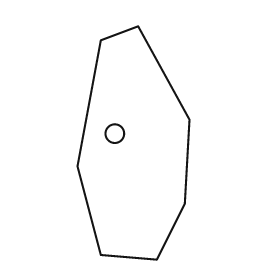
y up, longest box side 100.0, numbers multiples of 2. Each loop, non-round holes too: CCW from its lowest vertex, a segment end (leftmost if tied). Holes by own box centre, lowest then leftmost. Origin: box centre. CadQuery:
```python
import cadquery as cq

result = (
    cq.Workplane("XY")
    .moveTo(10.0, -50.0)
    .lineTo(22.0, -26.0)
    .lineTo(24.0, 10.0)
    .lineTo(2.0, 50.0)
    .lineTo(-14.0, 44.0)
    .lineTo(-24.0, -10.0)
    .lineTo(-14.0, -48.0)
    .close()
    .moveTo(-8.0, 4.0)
    .circle(4.0)
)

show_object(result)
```